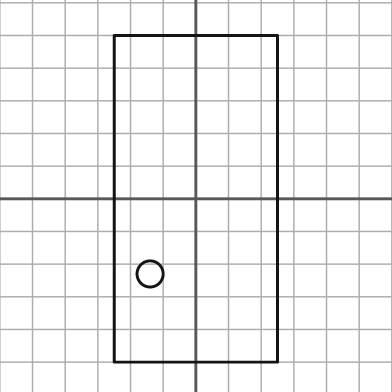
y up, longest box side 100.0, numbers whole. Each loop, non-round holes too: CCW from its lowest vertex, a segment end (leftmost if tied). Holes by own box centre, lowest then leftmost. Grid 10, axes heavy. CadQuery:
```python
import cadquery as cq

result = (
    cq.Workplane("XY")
    .moveTo(-25.0, -50.0)
    .lineTo(25.0, -50.0)
    .lineTo(25.0, 50.0)
    .lineTo(-25.0, 50.0)
    .close()
    .moveTo(-14.0, -23.0)
    .circle(4.0)
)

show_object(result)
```